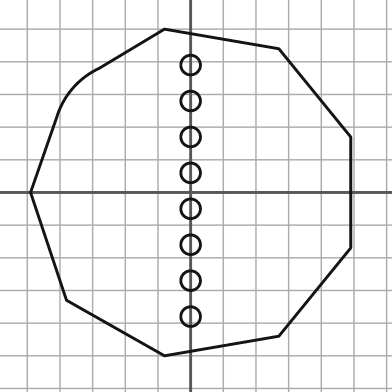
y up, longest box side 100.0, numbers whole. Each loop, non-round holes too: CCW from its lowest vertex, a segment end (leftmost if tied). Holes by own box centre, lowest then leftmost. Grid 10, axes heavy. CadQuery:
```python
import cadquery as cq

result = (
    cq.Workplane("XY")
    .moveTo(-8.0, -50.0)
    .lineTo(27.0, -44.0)
    .lineTo(49.0, -17.0)
    .lineTo(49.0, 17.0)
    .lineTo(27.0, 44.0)
    .lineTo(-8.0, 50.0)
    .lineTo(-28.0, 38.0)
    .threePointArc((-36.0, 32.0), (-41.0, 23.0))
    .lineTo(-49.0, 0.0)
    .lineTo(-38.0, -33.0)
    .close()
    .moveTo(0.0, -38.0)
    .circle(3.0)
    .moveTo(0.0, -27.0)
    .circle(3.0)
    .moveTo(0.0, -16.0)
    .circle(3.0)
    .moveTo(0.0, -5.0)
    .circle(3.0)
    .moveTo(0.0, 6.0)
    .circle(3.0)
    .moveTo(0.0, 17.0)
    .circle(3.0)
    .moveTo(0.0, 28.0)
    .circle(3.0)
    .moveTo(0.0, 39.0)
    .circle(3.0)
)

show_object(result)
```